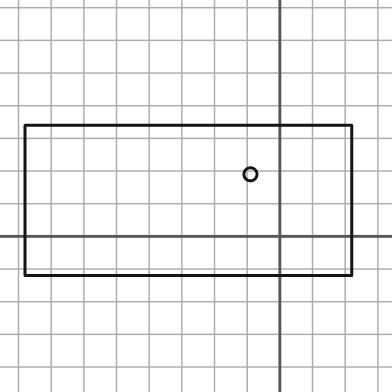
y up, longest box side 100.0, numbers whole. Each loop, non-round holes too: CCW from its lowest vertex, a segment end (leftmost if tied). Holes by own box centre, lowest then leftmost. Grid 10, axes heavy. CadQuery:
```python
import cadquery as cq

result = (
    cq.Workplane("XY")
    .moveTo(-78.0, -12.0)
    .lineTo(22.0, -12.0)
    .lineTo(22.0, 34.0)
    .lineTo(-78.0, 34.0)
    .close()
    .moveTo(-9.0, 19.0)
    .circle(2.0)
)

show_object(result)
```